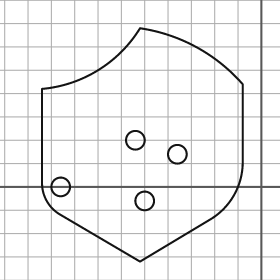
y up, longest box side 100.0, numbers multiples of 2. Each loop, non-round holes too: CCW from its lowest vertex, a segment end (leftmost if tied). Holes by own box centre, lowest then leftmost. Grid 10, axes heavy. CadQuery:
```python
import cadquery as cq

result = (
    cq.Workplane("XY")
    .moveTo(-52.0, -32.0)
    .lineTo(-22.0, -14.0)
    .threePointArc((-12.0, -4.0), (-8.0, 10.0))
    .lineTo(-8.0, 44.0)
    .threePointArc((-28.0, 60.0), (-52.0, 68.0))
    .threePointArc((-70.0, 50.0), (-94.0, 42.0))
    .lineTo(-94.0, 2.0)
    .threePointArc((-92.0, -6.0), (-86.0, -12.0))
    .close()
    .moveTo(-50.0, -6.0)
    .circle(4.0)
    .moveTo(-86.0, 0.0)
    .circle(4.0)
    .moveTo(-36.0, 14.0)
    .circle(4.0)
    .moveTo(-54.0, 20.0)
    .circle(4.0)
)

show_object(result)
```